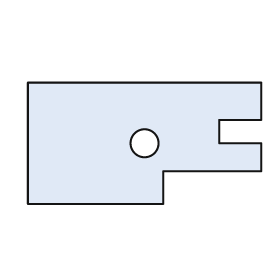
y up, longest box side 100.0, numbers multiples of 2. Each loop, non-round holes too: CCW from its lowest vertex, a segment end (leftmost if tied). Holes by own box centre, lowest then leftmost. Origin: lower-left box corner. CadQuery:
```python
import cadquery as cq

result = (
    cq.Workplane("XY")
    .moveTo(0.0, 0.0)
    .lineTo(58.0, 0.0)
    .lineTo(58.0, 14.0)
    .lineTo(100.0, 14.0)
    .lineTo(100.0, 26.0)
    .lineTo(82.0, 26.0)
    .lineTo(82.0, 36.0)
    .lineTo(100.0, 36.0)
    .lineTo(100.0, 52.0)
    .lineTo(0.0, 52.0)
    .close()
    .moveTo(50.0, 26.0)
    .circle(6.0)
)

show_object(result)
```